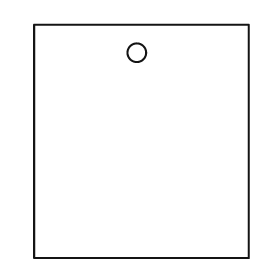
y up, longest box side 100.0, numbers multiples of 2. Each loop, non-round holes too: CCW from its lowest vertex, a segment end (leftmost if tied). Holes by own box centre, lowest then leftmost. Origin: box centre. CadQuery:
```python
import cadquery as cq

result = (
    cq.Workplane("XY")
    .moveTo(-46.0, -50.0)
    .lineTo(46.0, -50.0)
    .lineTo(46.0, 50.0)
    .lineTo(-46.0, 50.0)
    .close()
    .moveTo(-2.0, 38.0)
    .circle(4.0)
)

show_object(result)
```